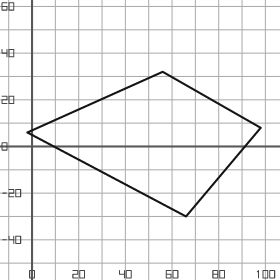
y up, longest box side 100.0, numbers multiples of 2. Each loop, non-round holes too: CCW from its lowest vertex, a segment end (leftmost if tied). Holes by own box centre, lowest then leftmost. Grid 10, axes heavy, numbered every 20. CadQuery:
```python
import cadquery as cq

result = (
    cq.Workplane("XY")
    .moveTo(66.0, -30.0)
    .lineTo(98.0, 8.0)
    .lineTo(56.0, 32.0)
    .lineTo(-2.0, 6.0)
    .close()
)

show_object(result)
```